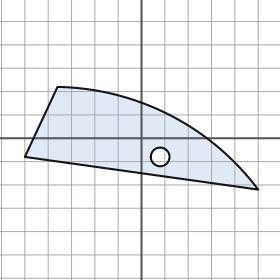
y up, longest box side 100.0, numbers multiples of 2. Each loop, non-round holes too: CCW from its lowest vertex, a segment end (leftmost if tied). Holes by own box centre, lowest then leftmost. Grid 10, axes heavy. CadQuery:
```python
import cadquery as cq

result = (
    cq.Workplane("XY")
    .moveTo(50.0, -22.0)
    .threePointArc((12.0, 10.0), (-36.0, 22.0))
    .lineTo(-50.0, -8.0)
    .close()
    .moveTo(8.0, -8.0)
    .circle(4.0)
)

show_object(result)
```